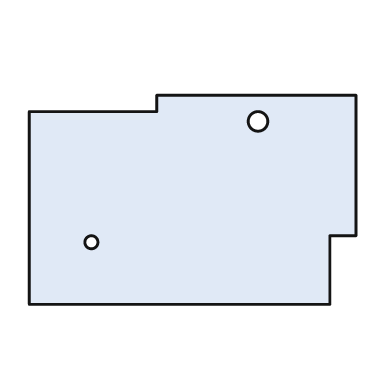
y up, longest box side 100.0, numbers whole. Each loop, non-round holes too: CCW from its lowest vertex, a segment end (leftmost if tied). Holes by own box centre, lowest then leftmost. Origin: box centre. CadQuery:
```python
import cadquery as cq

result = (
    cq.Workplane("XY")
    .moveTo(-50.0, -32.0)
    .lineTo(42.0, -32.0)
    .lineTo(42.0, -11.0)
    .lineTo(50.0, -11.0)
    .lineTo(50.0, 32.0)
    .lineTo(-11.0, 32.0)
    .lineTo(-11.0, 27.0)
    .lineTo(-50.0, 27.0)
    .close()
    .moveTo(-31.0, -13.0)
    .circle(2.0)
    .moveTo(20.0, 24.0)
    .circle(3.0)
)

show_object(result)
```